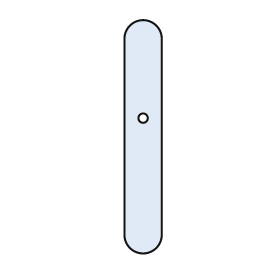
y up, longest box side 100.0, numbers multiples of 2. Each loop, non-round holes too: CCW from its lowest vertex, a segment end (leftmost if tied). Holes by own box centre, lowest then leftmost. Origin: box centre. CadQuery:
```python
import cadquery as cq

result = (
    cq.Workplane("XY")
    .moveTo(-8.0, -42.0)
    .threePointArc((0.0, -50.0), (8.0, -42.0))
    .lineTo(8.0, 42.0)
    .threePointArc((0.0, 50.0), (-8.0, 42.0))
    .close()
    .moveTo(0.0, 8.0)
    .circle(2.0)
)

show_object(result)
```